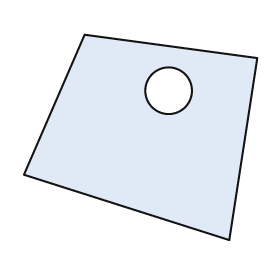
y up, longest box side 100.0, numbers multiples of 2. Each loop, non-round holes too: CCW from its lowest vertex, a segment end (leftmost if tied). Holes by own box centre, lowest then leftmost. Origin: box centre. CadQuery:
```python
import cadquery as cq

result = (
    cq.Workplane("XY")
    .moveTo(38.0, -44.0)
    .lineTo(50.0, 34.0)
    .lineTo(-24.0, 44.0)
    .lineTo(-50.0, -16.0)
    .close()
    .moveTo(12.0, 20.0)
    .circle(10.0)
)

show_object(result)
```